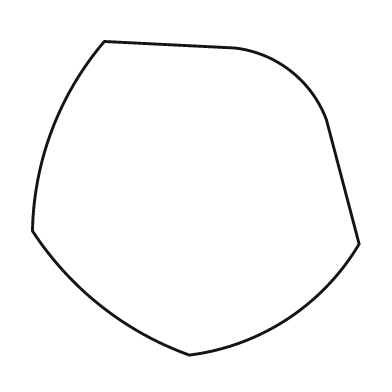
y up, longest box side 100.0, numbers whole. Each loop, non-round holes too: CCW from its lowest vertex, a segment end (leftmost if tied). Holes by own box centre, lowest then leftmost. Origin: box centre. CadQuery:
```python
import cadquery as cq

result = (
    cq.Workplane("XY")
    .moveTo(-2.0, -48.0)
    .threePointArc((28.0, -37.0), (50.0, -14.0))
    .lineTo(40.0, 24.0)
    .threePointArc((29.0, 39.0), (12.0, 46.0))
    .lineTo(-28.0, 48.0)
    .threePointArc((-44.0, 21.0), (-50.0, -10.0))
    .threePointArc((-29.0, -33.0), (-2.0, -48.0))
    .close()
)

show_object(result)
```